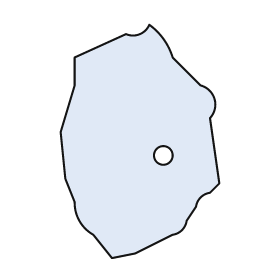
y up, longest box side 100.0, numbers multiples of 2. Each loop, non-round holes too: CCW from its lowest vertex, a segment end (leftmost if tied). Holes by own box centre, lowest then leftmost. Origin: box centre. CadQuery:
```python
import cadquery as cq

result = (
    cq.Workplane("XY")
    .moveTo(-12.0, -50.0)
    .lineTo(-2.0, -48.0)
    .lineTo(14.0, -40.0)
    .threePointArc((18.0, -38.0), (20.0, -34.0))
    .lineTo(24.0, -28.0)
    .threePointArc((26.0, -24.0), (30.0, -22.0))
    .lineTo(34.0, -18.0)
    .lineTo(30.0, 10.0)
    .threePointArc((32.0, 18.0), (26.0, 24.0))
    .lineTo(14.0, 36.0)
    .threePointArc((10.0, 44.0), (4.0, 50.0))
    .threePointArc((0.0, 46.0), (-6.0, 46.0))
    .lineTo(-28.0, 36.0)
    .lineTo(-28.0, 24.0)
    .lineTo(-34.0, 4.0)
    .lineTo(-32.0, -16.0)
    .lineTo(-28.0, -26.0)
    .threePointArc((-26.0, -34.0), (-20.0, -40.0))
    .close()
    .moveTo(10.0, -6.0)
    .circle(4.0)
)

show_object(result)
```